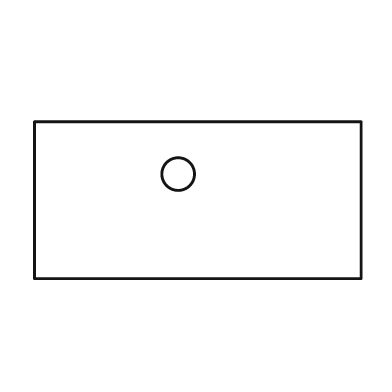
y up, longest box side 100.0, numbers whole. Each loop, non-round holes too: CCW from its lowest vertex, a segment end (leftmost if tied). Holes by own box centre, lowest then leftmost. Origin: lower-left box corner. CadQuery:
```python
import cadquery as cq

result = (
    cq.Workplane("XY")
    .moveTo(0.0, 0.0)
    .lineTo(100.0, 0.0)
    .lineTo(100.0, 48.0)
    .lineTo(0.0, 48.0)
    .close()
    .moveTo(44.0, 32.0)
    .circle(5.0)
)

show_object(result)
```